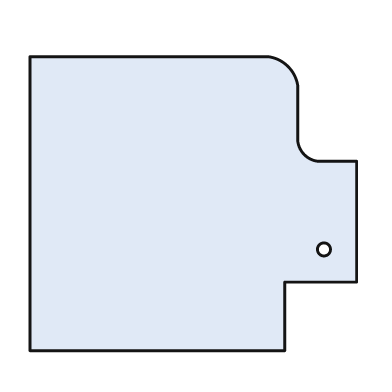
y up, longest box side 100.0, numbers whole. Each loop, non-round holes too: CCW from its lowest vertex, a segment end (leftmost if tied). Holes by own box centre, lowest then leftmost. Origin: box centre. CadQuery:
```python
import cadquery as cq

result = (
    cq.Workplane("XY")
    .moveTo(-50.0, -45.0)
    .lineTo(28.0, -45.0)
    .lineTo(28.0, -24.0)
    .lineTo(50.0, -24.0)
    .lineTo(50.0, 13.0)
    .lineTo(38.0, 13.0)
    .threePointArc((34.0, 15.0), (32.0, 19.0))
    .lineTo(32.0, 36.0)
    .threePointArc((29.0, 42.0), (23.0, 45.0))
    .lineTo(-50.0, 45.0)
    .close()
    .moveTo(40.0, -14.0)
    .circle(2.0)
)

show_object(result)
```